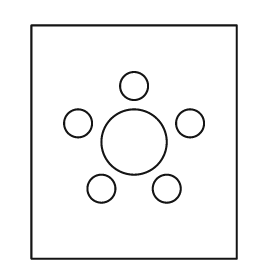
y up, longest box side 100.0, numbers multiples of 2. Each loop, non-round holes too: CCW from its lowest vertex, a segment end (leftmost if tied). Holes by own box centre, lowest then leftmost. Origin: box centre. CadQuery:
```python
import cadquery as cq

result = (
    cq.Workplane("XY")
    .moveTo(-44.0, -50.0)
    .lineTo(44.0, -50.0)
    .lineTo(44.0, 50.0)
    .lineTo(-44.0, 50.0)
    .close()
    .moveTo(-14.0, -20.0)
    .circle(6.0)
    .moveTo(14.0, -20.0)
    .circle(6.0)
    .moveTo(0.0, 0.0)
    .circle(14.0)
    .moveTo(-24.0, 8.0)
    .circle(6.0)
    .moveTo(24.0, 8.0)
    .circle(6.0)
    .moveTo(0.0, 24.0)
    .circle(6.0)
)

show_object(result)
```